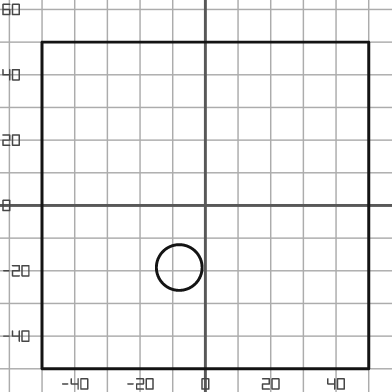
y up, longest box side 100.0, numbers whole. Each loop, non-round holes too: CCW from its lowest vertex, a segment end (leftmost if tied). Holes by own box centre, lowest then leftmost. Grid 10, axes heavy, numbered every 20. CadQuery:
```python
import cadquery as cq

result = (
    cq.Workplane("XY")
    .moveTo(-50.0, -50.0)
    .lineTo(50.0, -50.0)
    .lineTo(50.0, 50.0)
    .lineTo(-50.0, 50.0)
    .close()
    .moveTo(-8.0, -19.0)
    .circle(7.0)
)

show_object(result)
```